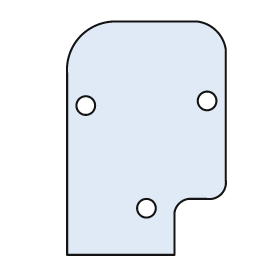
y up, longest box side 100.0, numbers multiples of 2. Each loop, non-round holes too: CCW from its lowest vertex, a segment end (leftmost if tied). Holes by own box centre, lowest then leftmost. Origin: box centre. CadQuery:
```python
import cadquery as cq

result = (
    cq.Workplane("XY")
    .moveTo(-34.0, -50.0)
    .lineTo(12.0, -50.0)
    .lineTo(12.0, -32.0)
    .threePointArc((14.0, -28.0), (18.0, -26.0))
    .lineTo(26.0, -26.0)
    .threePointArc((32.0, -24.0), (34.0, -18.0))
    .lineTo(34.0, 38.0)
    .threePointArc((30.0, 46.0), (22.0, 50.0))
    .lineTo(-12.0, 50.0)
    .threePointArc((-28.0, 44.0), (-34.0, 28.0))
    .close()
    .moveTo(0.0, -30.0)
    .circle(4.0)
    .moveTo(-26.0, 14.0)
    .circle(4.0)
    .moveTo(26.0, 16.0)
    .circle(4.0)
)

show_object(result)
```